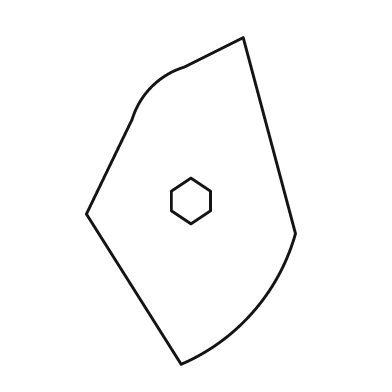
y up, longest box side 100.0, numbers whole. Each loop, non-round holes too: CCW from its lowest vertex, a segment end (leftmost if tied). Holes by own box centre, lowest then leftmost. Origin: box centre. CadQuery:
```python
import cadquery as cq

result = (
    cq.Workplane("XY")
    .moveTo(-3.0, -50.0)
    .threePointArc((19.0, -34.0), (32.0, -10.0))
    .lineTo(16.0, 50.0)
    .lineTo(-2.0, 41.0)
    .threePointArc((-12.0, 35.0), (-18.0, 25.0))
    .lineTo(-32.0, -4.0)
    .close()
    .moveTo(0.0, -7.0)
    .lineTo(6.0, -3.0)
    .lineTo(6.0, 3.0)
    .lineTo(0.0, 7.0)
    .lineTo(-6.0, 3.0)
    .lineTo(-6.0, -3.0)
    .close()
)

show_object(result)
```